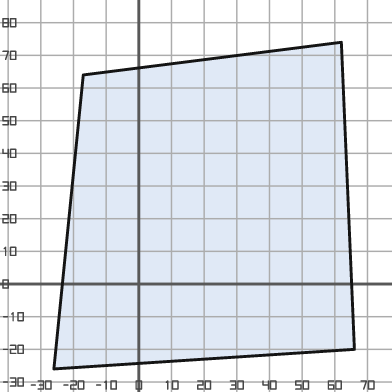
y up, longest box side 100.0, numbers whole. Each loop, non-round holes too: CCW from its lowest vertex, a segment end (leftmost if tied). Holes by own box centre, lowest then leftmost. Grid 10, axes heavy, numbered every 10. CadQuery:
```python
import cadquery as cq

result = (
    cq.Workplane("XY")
    .moveTo(-26.0, -26.0)
    .lineTo(66.0, -20.0)
    .lineTo(62.0, 74.0)
    .lineTo(-17.0, 64.0)
    .close()
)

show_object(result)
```